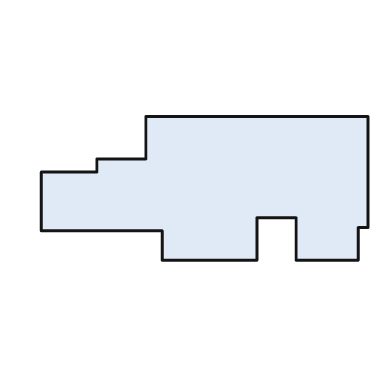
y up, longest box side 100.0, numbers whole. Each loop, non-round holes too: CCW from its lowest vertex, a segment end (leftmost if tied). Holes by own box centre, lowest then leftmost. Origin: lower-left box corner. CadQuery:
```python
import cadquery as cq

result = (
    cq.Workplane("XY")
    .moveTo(37.0, 0.0)
    .lineTo(66.0, 0.0)
    .lineTo(66.0, 13.0)
    .lineTo(78.0, 13.0)
    .lineTo(78.0, 0.0)
    .lineTo(97.0, 0.0)
    .lineTo(97.0, 10.0)
    .lineTo(100.0, 10.0)
    .lineTo(100.0, 44.0)
    .lineTo(32.0, 44.0)
    .lineTo(32.0, 31.0)
    .lineTo(17.0, 31.0)
    .lineTo(17.0, 27.0)
    .lineTo(0.0, 27.0)
    .lineTo(0.0, 9.0)
    .lineTo(37.0, 9.0)
    .close()
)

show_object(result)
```